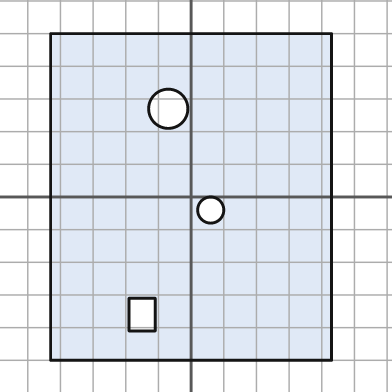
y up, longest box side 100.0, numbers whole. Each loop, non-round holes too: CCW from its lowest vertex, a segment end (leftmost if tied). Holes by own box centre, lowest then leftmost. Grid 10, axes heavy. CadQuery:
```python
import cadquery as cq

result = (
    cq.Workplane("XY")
    .moveTo(-43.0, -50.0)
    .lineTo(43.0, -50.0)
    .lineTo(43.0, 50.0)
    .lineTo(-43.0, 50.0)
    .close()
    .moveTo(-19.0, -41.0)
    .lineTo(-11.0, -41.0)
    .lineTo(-11.0, -31.0)
    .lineTo(-19.0, -31.0)
    .close()
    .moveTo(6.0, -4.0)
    .circle(4.0)
    .moveTo(-7.0, 27.0)
    .circle(6.0)
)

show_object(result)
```